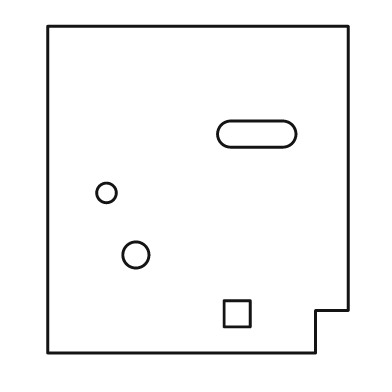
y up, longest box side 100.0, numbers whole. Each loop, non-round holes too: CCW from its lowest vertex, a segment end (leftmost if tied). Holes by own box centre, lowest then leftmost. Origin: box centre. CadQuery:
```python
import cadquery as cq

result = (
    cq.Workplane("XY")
    .moveTo(-46.0, -50.0)
    .lineTo(36.0, -50.0)
    .lineTo(36.0, -37.0)
    .lineTo(46.0, -37.0)
    .lineTo(46.0, 50.0)
    .lineTo(-46.0, 50.0)
    .close()
    .moveTo(8.0, -42.0)
    .lineTo(16.0, -42.0)
    .lineTo(16.0, -34.0)
    .lineTo(8.0, -34.0)
    .close()
    .moveTo(-19.0, -20.0)
    .circle(4.0)
    .moveTo(-28.0, -1.0)
    .circle(3.0)
    .moveTo(10.0, 13.0)
    .lineTo(26.0, 13.0)
    .threePointArc((30.0, 17.0), (26.0, 21.0))
    .lineTo(10.0, 21.0)
    .threePointArc((6.0, 17.0), (10.0, 13.0))
    .close()
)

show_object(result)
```